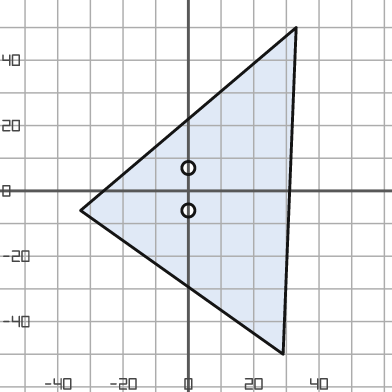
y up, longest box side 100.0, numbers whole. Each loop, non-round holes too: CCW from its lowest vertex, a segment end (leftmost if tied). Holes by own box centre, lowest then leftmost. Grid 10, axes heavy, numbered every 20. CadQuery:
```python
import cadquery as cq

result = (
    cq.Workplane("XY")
    .moveTo(29.0, -50.0)
    .lineTo(33.0, 50.0)
    .lineTo(-33.0, -6.0)
    .close()
    .moveTo(0.0, -6.0)
    .circle(2.0)
    .moveTo(0.0, 7.0)
    .circle(2.0)
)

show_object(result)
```